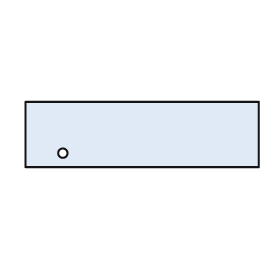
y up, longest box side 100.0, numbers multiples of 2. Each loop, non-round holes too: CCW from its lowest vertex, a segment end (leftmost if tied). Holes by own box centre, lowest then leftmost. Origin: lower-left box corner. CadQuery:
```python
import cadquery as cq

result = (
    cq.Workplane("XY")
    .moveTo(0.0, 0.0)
    .lineTo(100.0, 0.0)
    .lineTo(100.0, 28.0)
    .lineTo(0.0, 28.0)
    .close()
    .moveTo(16.0, 6.0)
    .circle(2.0)
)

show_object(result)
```